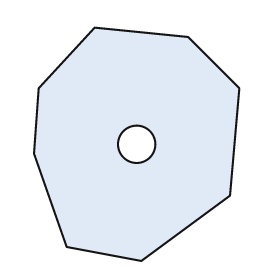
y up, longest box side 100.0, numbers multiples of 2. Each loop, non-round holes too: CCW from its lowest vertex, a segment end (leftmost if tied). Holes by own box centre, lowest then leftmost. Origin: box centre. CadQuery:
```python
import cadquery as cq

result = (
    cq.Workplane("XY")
    .moveTo(2.0, -50.0)
    .lineTo(40.0, -22.0)
    .lineTo(44.0, 24.0)
    .lineTo(22.0, 46.0)
    .lineTo(-18.0, 50.0)
    .lineTo(-42.0, 24.0)
    .lineTo(-44.0, -4.0)
    .lineTo(-30.0, -44.0)
    .close()
    .moveTo(0.0, 0.0)
    .circle(8.0)
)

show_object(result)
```